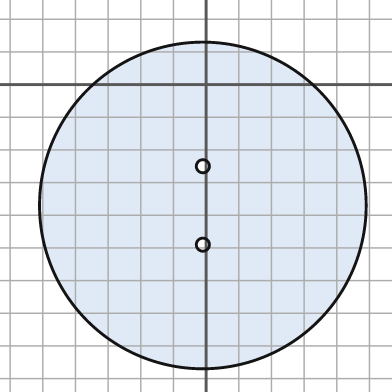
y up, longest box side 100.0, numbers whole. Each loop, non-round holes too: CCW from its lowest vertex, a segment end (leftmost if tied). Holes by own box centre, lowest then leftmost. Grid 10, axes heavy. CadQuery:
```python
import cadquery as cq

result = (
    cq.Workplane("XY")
    .moveTo(-1.0, -37.0)
    .circle(50.0)
    .moveTo(-1.0, -49.0)
    .circle(2.0)
    .moveTo(-1.0, -25.0)
    .circle(2.0)
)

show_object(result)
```